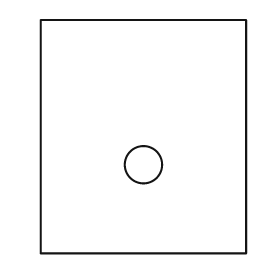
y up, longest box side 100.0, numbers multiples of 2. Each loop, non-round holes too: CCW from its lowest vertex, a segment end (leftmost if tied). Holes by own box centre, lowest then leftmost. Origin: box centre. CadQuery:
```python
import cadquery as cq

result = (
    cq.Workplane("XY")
    .moveTo(-44.0, -50.0)
    .lineTo(44.0, -50.0)
    .lineTo(44.0, 50.0)
    .lineTo(-44.0, 50.0)
    .close()
    .moveTo(0.0, -12.0)
    .circle(8.0)
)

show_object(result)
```